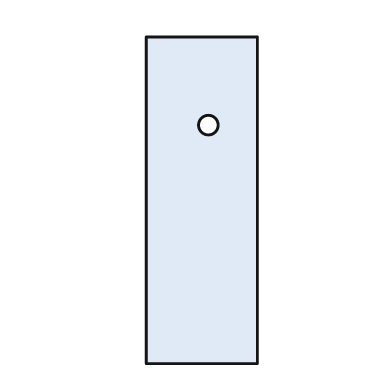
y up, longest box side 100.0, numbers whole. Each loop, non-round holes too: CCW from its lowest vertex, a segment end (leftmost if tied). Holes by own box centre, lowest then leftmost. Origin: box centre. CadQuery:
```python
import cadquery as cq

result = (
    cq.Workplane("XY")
    .moveTo(-17.0, -50.0)
    .lineTo(17.0, -50.0)
    .lineTo(17.0, 50.0)
    .lineTo(-17.0, 50.0)
    .close()
    .moveTo(2.0, 23.0)
    .circle(3.0)
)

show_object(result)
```